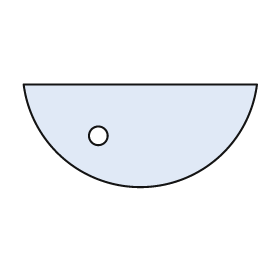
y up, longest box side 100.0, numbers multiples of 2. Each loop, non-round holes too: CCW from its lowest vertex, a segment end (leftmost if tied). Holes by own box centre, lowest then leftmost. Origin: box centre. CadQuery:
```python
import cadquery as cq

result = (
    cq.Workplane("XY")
    .moveTo(-50.0, 22.0)
    .threePointArc((0.0, -22.0), (50.0, 22.0))
    .close()
    .moveTo(-18.0, 0.0)
    .circle(4.0)
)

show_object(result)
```